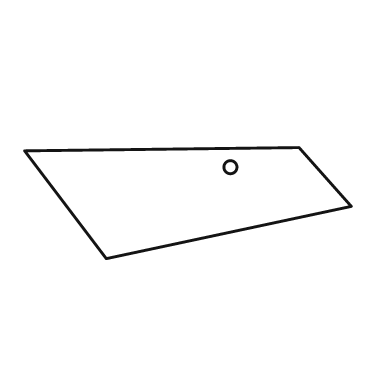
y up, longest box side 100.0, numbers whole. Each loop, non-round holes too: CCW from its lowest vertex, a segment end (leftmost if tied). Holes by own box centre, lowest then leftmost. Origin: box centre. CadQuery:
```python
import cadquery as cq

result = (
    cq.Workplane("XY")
    .moveTo(-25.0, -17.0)
    .lineTo(50.0, -1.0)
    .lineTo(34.0, 17.0)
    .lineTo(-50.0, 16.0)
    .close()
    .moveTo(13.0, 11.0)
    .circle(2.0)
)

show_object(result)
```